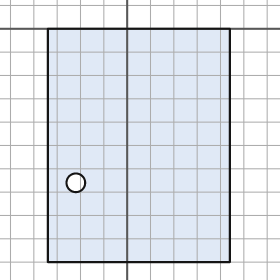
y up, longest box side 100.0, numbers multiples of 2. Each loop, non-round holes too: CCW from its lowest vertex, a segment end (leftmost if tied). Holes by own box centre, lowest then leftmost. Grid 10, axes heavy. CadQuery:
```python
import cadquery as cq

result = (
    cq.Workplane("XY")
    .moveTo(-34.0, -100.0)
    .lineTo(44.0, -100.0)
    .lineTo(44.0, 0.0)
    .lineTo(-34.0, 0.0)
    .close()
    .moveTo(-22.0, -66.0)
    .circle(4.0)
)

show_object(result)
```